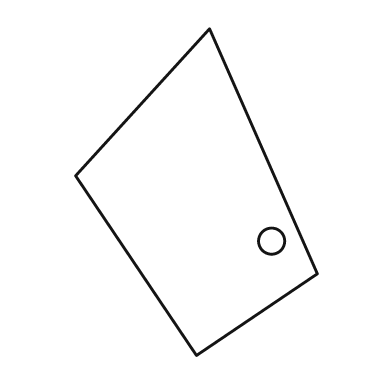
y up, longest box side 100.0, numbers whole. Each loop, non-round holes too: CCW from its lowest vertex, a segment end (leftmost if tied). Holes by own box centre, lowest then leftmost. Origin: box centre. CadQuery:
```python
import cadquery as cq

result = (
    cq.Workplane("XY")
    .moveTo(0.0, -50.0)
    .lineTo(37.0, -25.0)
    .lineTo(4.0, 50.0)
    .lineTo(-37.0, 5.0)
    .close()
    .moveTo(23.0, -15.0)
    .circle(4.0)
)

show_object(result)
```